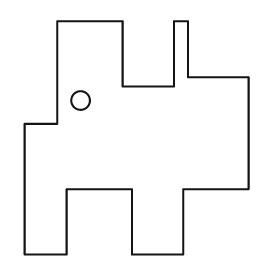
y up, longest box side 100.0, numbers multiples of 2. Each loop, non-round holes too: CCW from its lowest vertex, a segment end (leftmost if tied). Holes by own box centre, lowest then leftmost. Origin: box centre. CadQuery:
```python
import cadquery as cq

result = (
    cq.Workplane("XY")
    .moveTo(-48.0, -50.0)
    .lineTo(-30.0, -50.0)
    .lineTo(-30.0, -22.0)
    .lineTo(-2.0, -22.0)
    .lineTo(-2.0, -50.0)
    .lineTo(20.0, -50.0)
    .lineTo(20.0, -22.0)
    .lineTo(48.0, -22.0)
    .lineTo(48.0, 26.0)
    .lineTo(22.0, 26.0)
    .lineTo(22.0, 50.0)
    .lineTo(16.0, 50.0)
    .lineTo(16.0, 22.0)
    .lineTo(-6.0, 22.0)
    .lineTo(-6.0, 50.0)
    .lineTo(-34.0, 50.0)
    .lineTo(-34.0, 6.0)
    .lineTo(-48.0, 6.0)
    .close()
    .moveTo(-24.0, 16.0)
    .circle(4.0)
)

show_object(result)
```